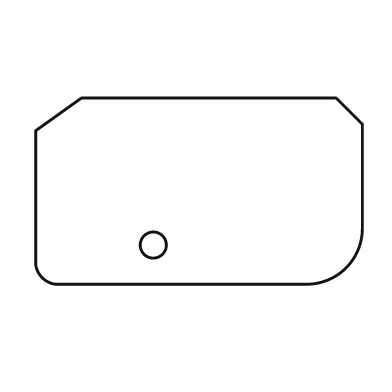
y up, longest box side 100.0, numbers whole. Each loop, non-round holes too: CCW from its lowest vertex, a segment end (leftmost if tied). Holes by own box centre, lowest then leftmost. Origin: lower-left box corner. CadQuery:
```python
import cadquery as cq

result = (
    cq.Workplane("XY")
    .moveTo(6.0, 0.0)
    .lineTo(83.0, 0.0)
    .threePointArc((95.0, 5.0), (100.0, 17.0))
    .lineTo(100.0, 49.0)
    .lineTo(92.0, 57.0)
    .lineTo(14.0, 57.0)
    .lineTo(0.0, 47.0)
    .lineTo(0.0, 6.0)
    .threePointArc((2.0, 2.0), (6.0, 0.0))
    .close()
    .moveTo(36.0, 12.0)
    .circle(4.0)
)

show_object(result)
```